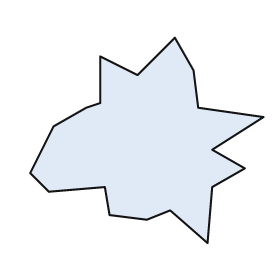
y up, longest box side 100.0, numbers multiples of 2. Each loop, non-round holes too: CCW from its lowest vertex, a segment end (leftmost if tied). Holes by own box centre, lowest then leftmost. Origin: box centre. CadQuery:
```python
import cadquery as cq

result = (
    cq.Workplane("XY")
    .moveTo(26.0, -44.0)
    .lineTo(28.0, -20.0)
    .lineTo(42.0, -12.0)
    .lineTo(28.0, -4.0)
    .lineTo(50.0, 10.0)
    .lineTo(22.0, 14.0)
    .lineTo(20.0, 30.0)
    .lineTo(12.0, 44.0)
    .lineTo(-4.0, 28.0)
    .lineTo(-20.0, 36.0)
    .lineTo(-20.0, 16.0)
    .lineTo(-26.0, 14.0)
    .lineTo(-40.0, 6.0)
    .lineTo(-50.0, -14.0)
    .lineTo(-42.0, -22.0)
    .lineTo(-18.0, -20.0)
    .lineTo(-16.0, -32.0)
    .lineTo(0.0, -34.0)
    .lineTo(10.0, -30.0)
    .close()
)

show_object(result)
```